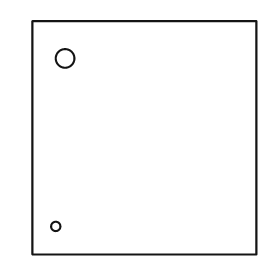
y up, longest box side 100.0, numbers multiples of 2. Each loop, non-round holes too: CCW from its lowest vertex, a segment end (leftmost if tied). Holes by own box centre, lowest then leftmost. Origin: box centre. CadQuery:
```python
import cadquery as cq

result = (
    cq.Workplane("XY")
    .moveTo(-48.0, -50.0)
    .lineTo(48.0, -50.0)
    .lineTo(48.0, 50.0)
    .lineTo(-48.0, 50.0)
    .close()
    .moveTo(-38.0, -38.0)
    .circle(2.0)
    .moveTo(-34.0, 34.0)
    .circle(4.0)
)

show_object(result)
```